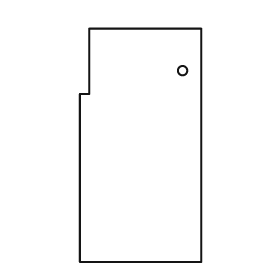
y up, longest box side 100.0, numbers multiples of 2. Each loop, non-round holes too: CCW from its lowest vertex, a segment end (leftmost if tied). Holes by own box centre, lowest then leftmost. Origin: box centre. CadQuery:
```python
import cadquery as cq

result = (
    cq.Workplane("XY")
    .moveTo(-26.0, -50.0)
    .lineTo(26.0, -50.0)
    .lineTo(26.0, 50.0)
    .lineTo(-22.0, 50.0)
    .lineTo(-22.0, 22.0)
    .lineTo(-26.0, 22.0)
    .close()
    .moveTo(18.0, 32.0)
    .circle(2.0)
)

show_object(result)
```